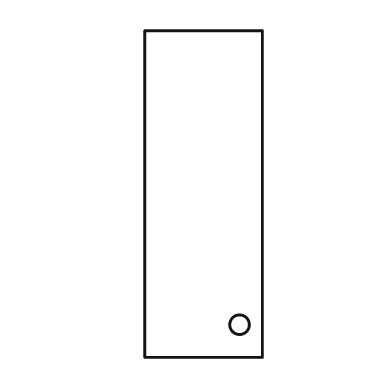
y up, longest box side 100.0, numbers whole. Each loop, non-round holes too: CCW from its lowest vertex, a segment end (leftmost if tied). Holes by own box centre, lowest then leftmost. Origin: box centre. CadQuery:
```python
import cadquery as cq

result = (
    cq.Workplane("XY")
    .moveTo(-18.0, -50.0)
    .lineTo(18.0, -50.0)
    .lineTo(18.0, 50.0)
    .lineTo(-18.0, 50.0)
    .close()
    .moveTo(11.0, -40.0)
    .circle(3.0)
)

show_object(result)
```